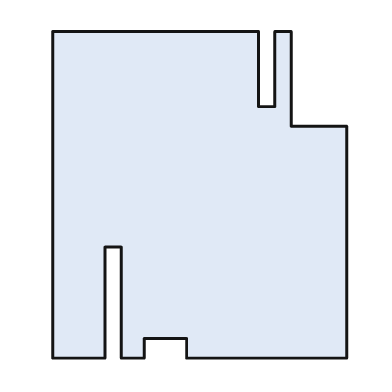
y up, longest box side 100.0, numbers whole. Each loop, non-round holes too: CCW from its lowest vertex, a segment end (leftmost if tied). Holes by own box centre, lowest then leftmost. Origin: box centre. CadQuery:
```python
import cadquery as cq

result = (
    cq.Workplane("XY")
    .moveTo(-45.0, -50.0)
    .lineTo(-29.0, -50.0)
    .lineTo(-29.0, -16.0)
    .lineTo(-24.0, -16.0)
    .lineTo(-24.0, -50.0)
    .lineTo(-17.0, -50.0)
    .lineTo(-17.0, -44.0)
    .lineTo(-4.0, -44.0)
    .lineTo(-4.0, -50.0)
    .lineTo(45.0, -50.0)
    .lineTo(45.0, 21.0)
    .lineTo(28.0, 21.0)
    .lineTo(28.0, 50.0)
    .lineTo(23.0, 50.0)
    .lineTo(23.0, 27.0)
    .lineTo(18.0, 27.0)
    .lineTo(18.0, 50.0)
    .lineTo(-45.0, 50.0)
    .close()
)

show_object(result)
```